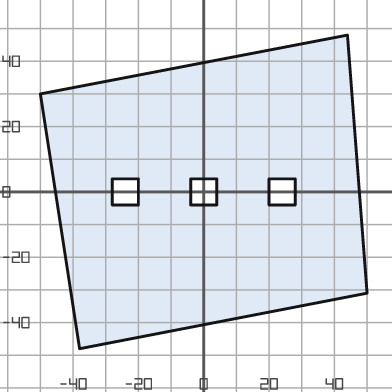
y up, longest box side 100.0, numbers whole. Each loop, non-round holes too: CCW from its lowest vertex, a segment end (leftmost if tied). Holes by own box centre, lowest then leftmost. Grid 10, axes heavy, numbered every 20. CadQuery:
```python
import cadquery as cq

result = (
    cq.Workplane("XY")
    .moveTo(-38.0, -48.0)
    .lineTo(50.0, -31.0)
    .lineTo(44.0, 48.0)
    .lineTo(-50.0, 30.0)
    .close()
    .moveTo(-28.0, -4.0)
    .lineTo(-20.0, -4.0)
    .lineTo(-20.0, 4.0)
    .lineTo(-28.0, 4.0)
    .close()
    .moveTo(-4.0, -4.0)
    .lineTo(4.0, -4.0)
    .lineTo(4.0, 4.0)
    .lineTo(-4.0, 4.0)
    .close()
    .moveTo(20.0, -4.0)
    .lineTo(28.0, -4.0)
    .lineTo(28.0, 4.0)
    .lineTo(20.0, 4.0)
    .close()
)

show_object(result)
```